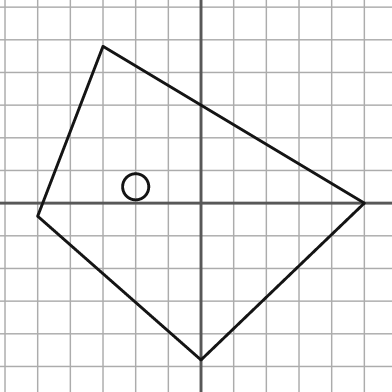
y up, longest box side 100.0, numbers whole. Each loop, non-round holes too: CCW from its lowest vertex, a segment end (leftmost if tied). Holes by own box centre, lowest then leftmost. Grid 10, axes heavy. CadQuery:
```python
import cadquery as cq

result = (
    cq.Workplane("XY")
    .moveTo(0.0, -48.0)
    .lineTo(50.0, 0.0)
    .lineTo(-30.0, 48.0)
    .lineTo(-50.0, -4.0)
    .close()
    .moveTo(-20.0, 5.0)
    .circle(4.0)
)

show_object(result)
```